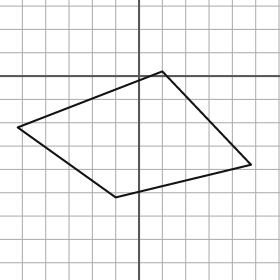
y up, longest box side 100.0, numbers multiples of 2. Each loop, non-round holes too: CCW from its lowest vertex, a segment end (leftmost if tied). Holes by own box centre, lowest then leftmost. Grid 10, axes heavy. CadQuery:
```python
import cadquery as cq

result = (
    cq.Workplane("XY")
    .moveTo(-10.0, -52.0)
    .lineTo(48.0, -38.0)
    .lineTo(10.0, 2.0)
    .lineTo(-52.0, -22.0)
    .close()
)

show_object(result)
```